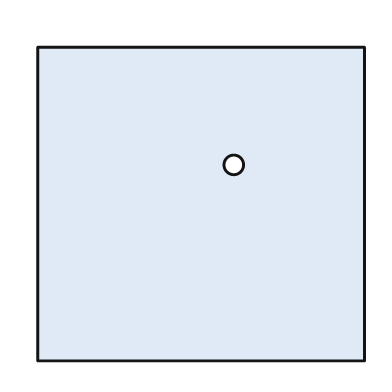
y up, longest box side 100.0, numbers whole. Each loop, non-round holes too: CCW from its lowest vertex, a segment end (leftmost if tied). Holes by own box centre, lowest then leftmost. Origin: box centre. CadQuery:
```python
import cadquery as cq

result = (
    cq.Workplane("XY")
    .moveTo(-50.0, -48.0)
    .lineTo(50.0, -48.0)
    .lineTo(50.0, 48.0)
    .lineTo(-50.0, 48.0)
    .close()
    .moveTo(10.0, 12.0)
    .circle(3.0)
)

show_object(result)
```